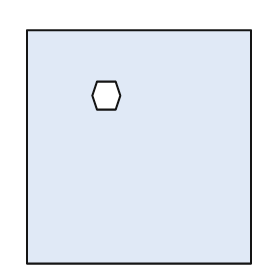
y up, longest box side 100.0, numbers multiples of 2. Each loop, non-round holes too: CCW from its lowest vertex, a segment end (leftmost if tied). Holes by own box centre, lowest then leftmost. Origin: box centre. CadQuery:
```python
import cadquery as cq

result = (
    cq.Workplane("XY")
    .moveTo(-48.0, -50.0)
    .lineTo(48.0, -50.0)
    .lineTo(48.0, 50.0)
    .lineTo(-48.0, 50.0)
    .close()
    .moveTo(-18.0, 16.0)
    .lineTo(-10.0, 16.0)
    .lineTo(-8.0, 22.0)
    .lineTo(-10.0, 28.0)
    .lineTo(-18.0, 28.0)
    .lineTo(-20.0, 22.0)
    .close()
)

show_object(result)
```